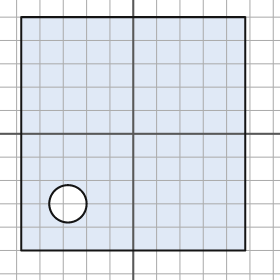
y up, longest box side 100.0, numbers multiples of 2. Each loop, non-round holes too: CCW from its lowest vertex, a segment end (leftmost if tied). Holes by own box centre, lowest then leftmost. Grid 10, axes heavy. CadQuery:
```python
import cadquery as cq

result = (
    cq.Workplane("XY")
    .moveTo(-48.0, -50.0)
    .lineTo(48.0, -50.0)
    .lineTo(48.0, 50.0)
    .lineTo(-48.0, 50.0)
    .close()
    .moveTo(-28.0, -30.0)
    .circle(8.0)
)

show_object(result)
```